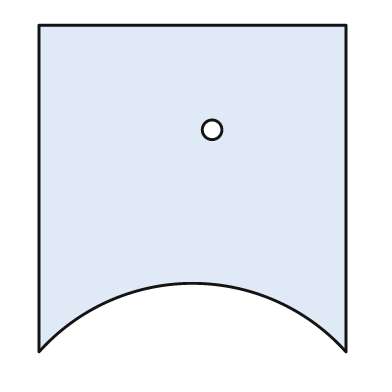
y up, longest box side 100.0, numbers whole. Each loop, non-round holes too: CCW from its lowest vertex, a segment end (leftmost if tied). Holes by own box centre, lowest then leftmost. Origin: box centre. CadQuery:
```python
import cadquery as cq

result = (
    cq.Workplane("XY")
    .moveTo(-47.0, -50.0)
    .threePointArc((0.0, -29.0), (47.0, -50.0))
    .lineTo(47.0, 50.0)
    .lineTo(-47.0, 50.0)
    .close()
    .moveTo(6.0, 18.0)
    .circle(3.0)
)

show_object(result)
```